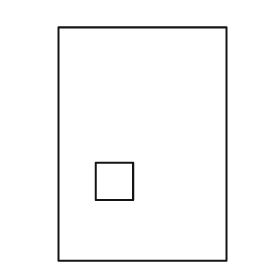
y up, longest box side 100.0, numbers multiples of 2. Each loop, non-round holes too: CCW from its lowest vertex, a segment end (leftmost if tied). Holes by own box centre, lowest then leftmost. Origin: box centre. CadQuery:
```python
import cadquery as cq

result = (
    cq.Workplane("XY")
    .moveTo(-36.0, -50.0)
    .lineTo(36.0, -50.0)
    .lineTo(36.0, 50.0)
    .lineTo(-36.0, 50.0)
    .close()
    .moveTo(-20.0, -24.0)
    .lineTo(-4.0, -24.0)
    .lineTo(-4.0, -8.0)
    .lineTo(-20.0, -8.0)
    .close()
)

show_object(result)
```